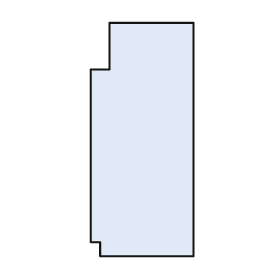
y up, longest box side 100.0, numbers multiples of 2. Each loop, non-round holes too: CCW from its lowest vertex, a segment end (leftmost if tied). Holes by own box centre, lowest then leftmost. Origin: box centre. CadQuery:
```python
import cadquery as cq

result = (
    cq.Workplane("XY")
    .moveTo(-18.0, -50.0)
    .lineTo(22.0, -50.0)
    .lineTo(22.0, 50.0)
    .lineTo(-14.0, 50.0)
    .lineTo(-14.0, 30.0)
    .lineTo(-22.0, 30.0)
    .lineTo(-22.0, -44.0)
    .lineTo(-18.0, -44.0)
    .close()
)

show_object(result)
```